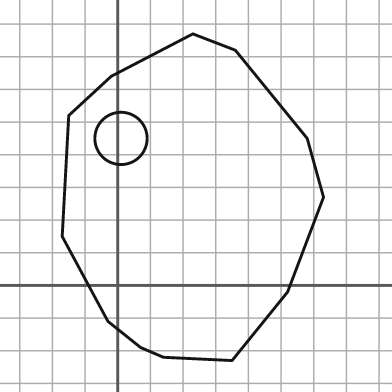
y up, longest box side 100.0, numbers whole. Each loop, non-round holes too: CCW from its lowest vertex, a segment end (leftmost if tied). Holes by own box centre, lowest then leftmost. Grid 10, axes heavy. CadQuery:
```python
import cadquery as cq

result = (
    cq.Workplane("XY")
    .moveTo(35.0, -23.0)
    .lineTo(52.0, -2.0)
    .lineTo(63.0, 27.0)
    .lineTo(58.0, 45.0)
    .lineTo(36.0, 72.0)
    .lineTo(23.0, 77.0)
    .lineTo(-2.0, 64.0)
    .lineTo(-15.0, 52.0)
    .lineTo(-17.0, 15.0)
    .lineTo(-3.0, -11.0)
    .lineTo(7.0, -19.0)
    .lineTo(14.0, -22.0)
    .close()
    .moveTo(1.0, 45.0)
    .circle(8.0)
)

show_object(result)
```